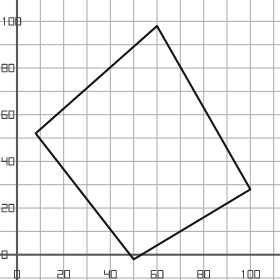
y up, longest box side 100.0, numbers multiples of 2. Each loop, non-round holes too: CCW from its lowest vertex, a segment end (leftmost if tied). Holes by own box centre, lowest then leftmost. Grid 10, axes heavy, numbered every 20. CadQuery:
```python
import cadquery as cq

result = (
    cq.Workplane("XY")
    .moveTo(50.0, -2.0)
    .lineTo(100.0, 28.0)
    .lineTo(60.0, 98.0)
    .lineTo(8.0, 52.0)
    .close()
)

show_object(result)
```